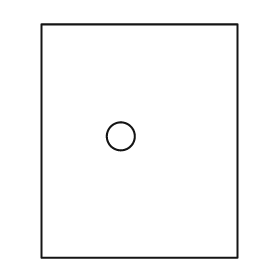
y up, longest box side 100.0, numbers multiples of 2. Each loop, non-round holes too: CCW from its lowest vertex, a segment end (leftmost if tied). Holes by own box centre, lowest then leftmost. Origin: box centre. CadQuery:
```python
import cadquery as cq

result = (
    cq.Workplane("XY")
    .moveTo(-42.0, -50.0)
    .lineTo(42.0, -50.0)
    .lineTo(42.0, 50.0)
    .lineTo(-42.0, 50.0)
    .close()
    .moveTo(-8.0, 2.0)
    .circle(6.0)
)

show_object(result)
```